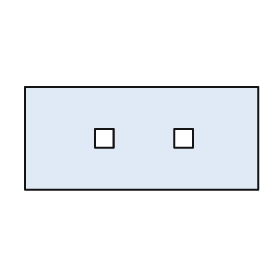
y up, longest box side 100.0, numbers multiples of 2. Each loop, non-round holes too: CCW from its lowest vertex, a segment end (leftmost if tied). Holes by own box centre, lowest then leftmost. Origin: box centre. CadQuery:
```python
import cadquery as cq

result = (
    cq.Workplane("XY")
    .moveTo(-50.0, -22.0)
    .lineTo(50.0, -22.0)
    .lineTo(50.0, 22.0)
    .lineTo(-50.0, 22.0)
    .close()
    .moveTo(-20.0, -4.0)
    .lineTo(-12.0, -4.0)
    .lineTo(-12.0, 4.0)
    .lineTo(-20.0, 4.0)
    .close()
    .moveTo(14.0, -4.0)
    .lineTo(22.0, -4.0)
    .lineTo(22.0, 4.0)
    .lineTo(14.0, 4.0)
    .close()
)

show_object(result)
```